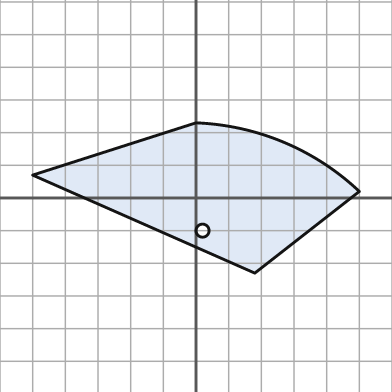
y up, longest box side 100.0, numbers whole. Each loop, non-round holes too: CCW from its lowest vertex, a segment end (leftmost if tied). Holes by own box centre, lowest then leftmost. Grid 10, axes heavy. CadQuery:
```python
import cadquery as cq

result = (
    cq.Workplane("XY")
    .moveTo(18.0, -23.0)
    .lineTo(50.0, 2.0)
    .threePointArc((27.0, 17.0), (0.0, 23.0))
    .lineTo(-50.0, 7.0)
    .close()
    .moveTo(2.0, -10.0)
    .circle(2.0)
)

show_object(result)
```